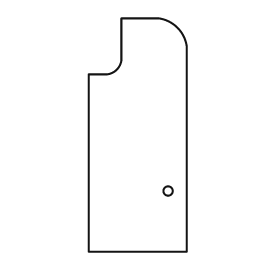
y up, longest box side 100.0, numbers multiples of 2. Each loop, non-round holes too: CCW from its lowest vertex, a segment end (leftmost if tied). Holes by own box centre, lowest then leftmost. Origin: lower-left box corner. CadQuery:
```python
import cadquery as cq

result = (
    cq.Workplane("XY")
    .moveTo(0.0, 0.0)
    .lineTo(42.0, 0.0)
    .lineTo(42.0, 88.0)
    .threePointArc((38.0, 96.0), (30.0, 100.0))
    .lineTo(14.0, 100.0)
    .lineTo(14.0, 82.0)
    .threePointArc((12.0, 78.0), (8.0, 76.0))
    .lineTo(0.0, 76.0)
    .close()
    .moveTo(34.0, 26.0)
    .circle(2.0)
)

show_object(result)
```